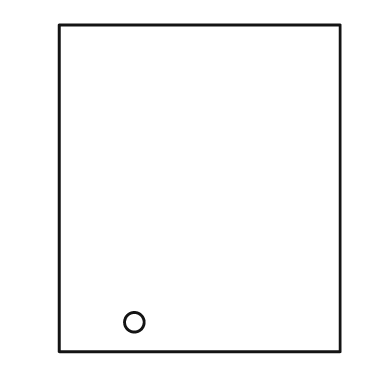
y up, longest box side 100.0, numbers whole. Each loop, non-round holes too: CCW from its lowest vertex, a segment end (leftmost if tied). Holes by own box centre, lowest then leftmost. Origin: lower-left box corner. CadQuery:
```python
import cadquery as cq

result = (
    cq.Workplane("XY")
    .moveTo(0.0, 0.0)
    .lineTo(86.0, 0.0)
    .lineTo(86.0, 100.0)
    .lineTo(0.0, 100.0)
    .close()
    .moveTo(23.0, 9.0)
    .circle(3.0)
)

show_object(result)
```